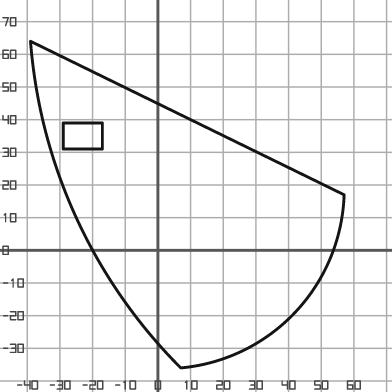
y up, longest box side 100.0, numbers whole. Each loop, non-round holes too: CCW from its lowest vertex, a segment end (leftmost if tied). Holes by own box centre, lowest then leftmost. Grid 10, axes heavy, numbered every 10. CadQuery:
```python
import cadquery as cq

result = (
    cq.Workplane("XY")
    .moveTo(7.0, -36.0)
    .threePointArc((42.0, -19.0), (57.0, 17.0))
    .lineTo(-39.0, 64.0)
    .threePointArc((-25.0, 10.0), (7.0, -36.0))
    .close()
    .moveTo(-29.0, 31.0)
    .lineTo(-17.0, 31.0)
    .lineTo(-17.0, 39.0)
    .lineTo(-29.0, 39.0)
    .close()
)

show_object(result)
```